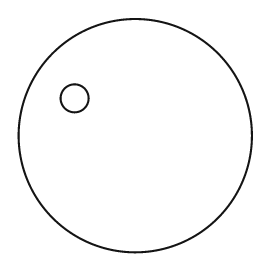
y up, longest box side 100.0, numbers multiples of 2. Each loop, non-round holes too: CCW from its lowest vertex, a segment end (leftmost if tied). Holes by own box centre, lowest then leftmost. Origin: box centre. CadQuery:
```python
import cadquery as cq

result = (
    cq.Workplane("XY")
    .moveTo(0.0, 0.0)
    .circle(50.0)
    .moveTo(-26.0, 16.0)
    .circle(6.0)
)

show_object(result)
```